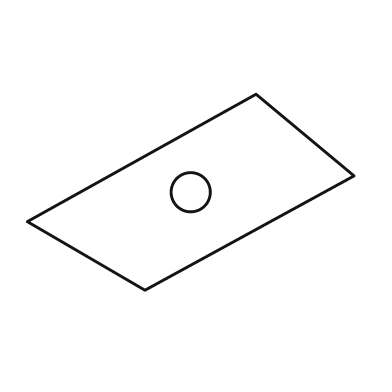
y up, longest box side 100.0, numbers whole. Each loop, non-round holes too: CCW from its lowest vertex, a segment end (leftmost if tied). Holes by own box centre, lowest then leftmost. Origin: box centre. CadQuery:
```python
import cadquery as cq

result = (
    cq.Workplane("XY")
    .moveTo(-14.0, -30.0)
    .lineTo(50.0, 5.0)
    .lineTo(20.0, 30.0)
    .lineTo(-50.0, -9.0)
    .close()
    .moveTo(0.0, 0.0)
    .circle(6.0)
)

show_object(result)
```